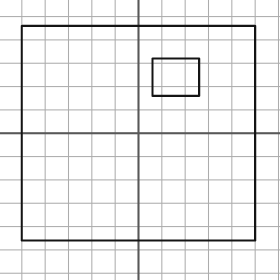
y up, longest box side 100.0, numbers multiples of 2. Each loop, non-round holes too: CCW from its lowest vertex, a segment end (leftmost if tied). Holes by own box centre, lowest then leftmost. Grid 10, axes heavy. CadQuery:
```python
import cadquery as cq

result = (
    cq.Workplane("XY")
    .moveTo(-50.0, -46.0)
    .lineTo(50.0, -46.0)
    .lineTo(50.0, 46.0)
    .lineTo(-50.0, 46.0)
    .close()
    .moveTo(6.0, 16.0)
    .lineTo(26.0, 16.0)
    .lineTo(26.0, 32.0)
    .lineTo(6.0, 32.0)
    .close()
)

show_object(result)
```